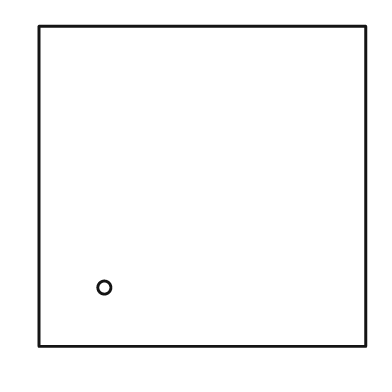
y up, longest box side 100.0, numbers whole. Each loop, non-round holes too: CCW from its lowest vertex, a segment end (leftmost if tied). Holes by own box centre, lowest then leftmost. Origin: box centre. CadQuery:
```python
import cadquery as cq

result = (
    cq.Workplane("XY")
    .moveTo(-50.0, -49.0)
    .lineTo(50.0, -49.0)
    .lineTo(50.0, 49.0)
    .lineTo(-50.0, 49.0)
    .close()
    .moveTo(-30.0, -31.0)
    .circle(2.0)
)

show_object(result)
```